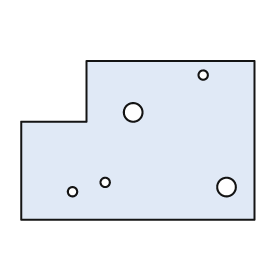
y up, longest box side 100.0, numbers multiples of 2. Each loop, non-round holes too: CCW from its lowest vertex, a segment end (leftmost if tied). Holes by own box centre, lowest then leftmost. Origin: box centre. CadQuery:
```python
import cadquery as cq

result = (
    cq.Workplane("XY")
    .moveTo(-50.0, -34.0)
    .lineTo(50.0, -34.0)
    .lineTo(50.0, 34.0)
    .lineTo(-22.0, 34.0)
    .lineTo(-22.0, 8.0)
    .lineTo(-50.0, 8.0)
    .close()
    .moveTo(-28.0, -22.0)
    .circle(2.0)
    .moveTo(38.0, -20.0)
    .circle(4.0)
    .moveTo(-14.0, -18.0)
    .circle(2.0)
    .moveTo(-2.0, 12.0)
    .circle(4.0)
    .moveTo(28.0, 28.0)
    .circle(2.0)
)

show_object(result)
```